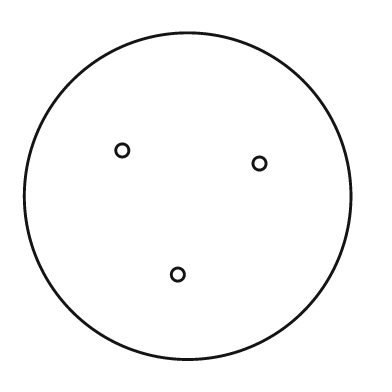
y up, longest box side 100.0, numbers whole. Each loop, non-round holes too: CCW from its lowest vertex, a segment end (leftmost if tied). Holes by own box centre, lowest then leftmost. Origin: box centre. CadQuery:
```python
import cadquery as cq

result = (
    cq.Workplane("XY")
    .moveTo(0.0, 0.0)
    .circle(50.0)
    .moveTo(-3.0, -24.0)
    .circle(2.0)
    .moveTo(22.0, 10.0)
    .circle(2.0)
    .moveTo(-20.0, 14.0)
    .circle(2.0)
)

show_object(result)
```